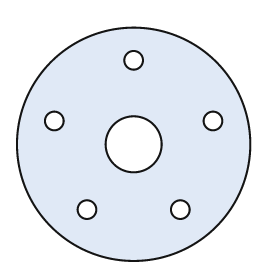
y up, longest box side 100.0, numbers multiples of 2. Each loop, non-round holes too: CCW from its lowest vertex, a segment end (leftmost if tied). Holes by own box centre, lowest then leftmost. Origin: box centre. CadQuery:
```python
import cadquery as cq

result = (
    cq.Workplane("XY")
    .moveTo(0.0, 0.0)
    .circle(50.0)
    .moveTo(-20.0, -28.0)
    .circle(4.0)
    .moveTo(20.0, -28.0)
    .circle(4.0)
    .moveTo(0.0, 0.0)
    .circle(12.0)
    .moveTo(-34.0, 10.0)
    .circle(4.0)
    .moveTo(34.0, 10.0)
    .circle(4.0)
    .moveTo(0.0, 36.0)
    .circle(4.0)
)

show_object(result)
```